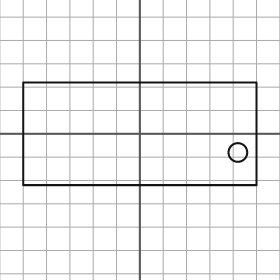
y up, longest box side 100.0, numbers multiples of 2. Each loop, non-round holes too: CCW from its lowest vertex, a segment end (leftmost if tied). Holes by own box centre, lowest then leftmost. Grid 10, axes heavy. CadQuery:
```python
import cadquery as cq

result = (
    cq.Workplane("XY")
    .moveTo(-50.0, -22.0)
    .lineTo(50.0, -22.0)
    .lineTo(50.0, 22.0)
    .lineTo(-50.0, 22.0)
    .close()
    .moveTo(42.0, -8.0)
    .circle(4.0)
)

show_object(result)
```